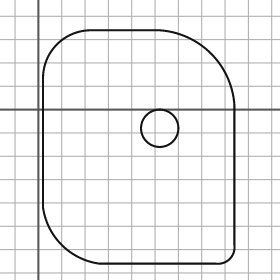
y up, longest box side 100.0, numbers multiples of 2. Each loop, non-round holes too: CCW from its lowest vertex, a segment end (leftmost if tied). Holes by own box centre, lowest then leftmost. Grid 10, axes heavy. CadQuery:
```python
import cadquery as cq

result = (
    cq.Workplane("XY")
    .moveTo(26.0, -66.0)
    .lineTo(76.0, -66.0)
    .threePointArc((82.0, -64.0), (84.0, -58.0))
    .lineTo(84.0, 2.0)
    .threePointArc((74.0, 24.0), (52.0, 34.0))
    .lineTo(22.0, 34.0)
    .threePointArc((8.0, 28.0), (2.0, 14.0))
    .lineTo(2.0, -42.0)
    .threePointArc((10.0, -58.0), (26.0, -66.0))
    .close()
    .moveTo(52.0, -8.0)
    .circle(8.0)
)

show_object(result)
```